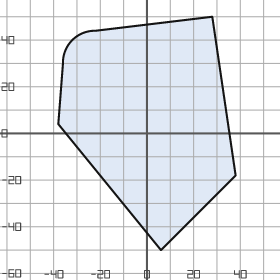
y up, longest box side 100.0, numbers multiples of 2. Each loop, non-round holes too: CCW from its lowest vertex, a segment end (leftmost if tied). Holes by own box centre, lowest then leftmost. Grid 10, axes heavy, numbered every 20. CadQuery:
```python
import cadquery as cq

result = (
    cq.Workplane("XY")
    .moveTo(6.0, -50.0)
    .lineTo(38.0, -18.0)
    .lineTo(28.0, 50.0)
    .lineTo(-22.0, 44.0)
    .threePointArc((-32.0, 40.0), (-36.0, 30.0))
    .lineTo(-38.0, 4.0)
    .close()
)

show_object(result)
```